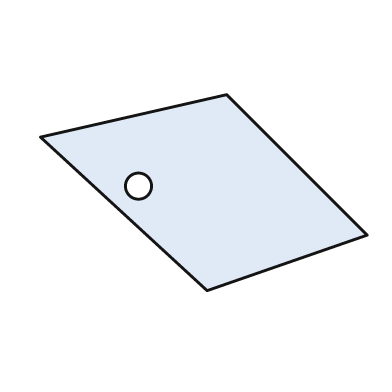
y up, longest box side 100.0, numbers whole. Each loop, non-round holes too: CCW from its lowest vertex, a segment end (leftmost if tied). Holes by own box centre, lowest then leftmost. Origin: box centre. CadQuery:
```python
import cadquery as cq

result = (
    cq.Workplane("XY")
    .moveTo(1.0, -30.0)
    .lineTo(50.0, -13.0)
    .lineTo(7.0, 30.0)
    .lineTo(-50.0, 17.0)
    .close()
    .moveTo(-20.0, 2.0)
    .circle(4.0)
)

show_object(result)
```